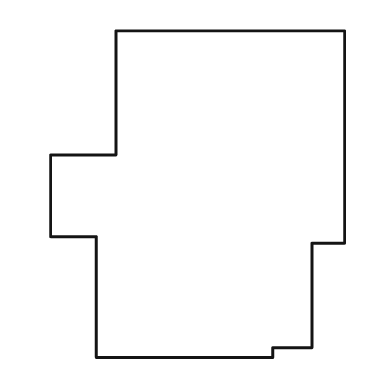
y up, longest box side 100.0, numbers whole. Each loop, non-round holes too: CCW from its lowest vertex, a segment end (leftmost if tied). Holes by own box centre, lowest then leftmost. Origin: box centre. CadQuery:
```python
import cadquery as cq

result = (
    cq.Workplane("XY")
    .moveTo(-31.0, -50.0)
    .lineTo(23.0, -50.0)
    .lineTo(23.0, -47.0)
    .lineTo(35.0, -47.0)
    .lineTo(35.0, -15.0)
    .lineTo(45.0, -15.0)
    .lineTo(45.0, 50.0)
    .lineTo(-25.0, 50.0)
    .lineTo(-25.0, 12.0)
    .lineTo(-45.0, 12.0)
    .lineTo(-45.0, -13.0)
    .lineTo(-31.0, -13.0)
    .close()
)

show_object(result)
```